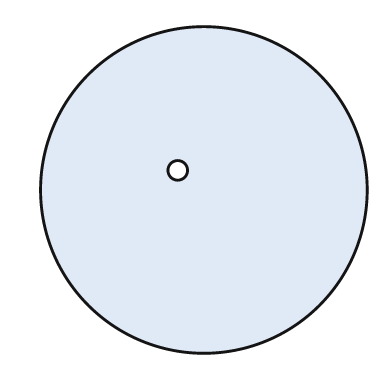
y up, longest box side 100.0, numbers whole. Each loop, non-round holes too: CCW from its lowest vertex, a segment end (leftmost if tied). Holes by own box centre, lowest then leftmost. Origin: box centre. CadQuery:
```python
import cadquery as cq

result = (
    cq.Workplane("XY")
    .moveTo(0.0, 0.0)
    .circle(50.0)
    .moveTo(-8.0, 6.0)
    .circle(3.0)
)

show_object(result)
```